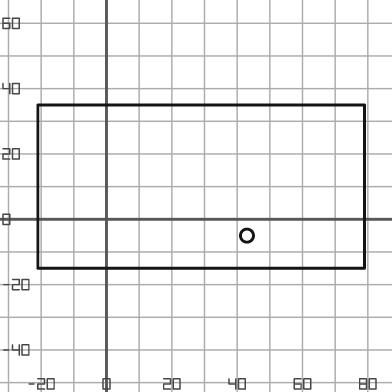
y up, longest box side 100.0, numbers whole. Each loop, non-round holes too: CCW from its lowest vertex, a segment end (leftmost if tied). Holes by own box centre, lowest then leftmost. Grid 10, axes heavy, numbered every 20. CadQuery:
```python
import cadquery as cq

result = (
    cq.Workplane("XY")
    .moveTo(-21.0, -15.0)
    .lineTo(79.0, -15.0)
    .lineTo(79.0, 35.0)
    .lineTo(-21.0, 35.0)
    .close()
    .moveTo(43.0, -5.0)
    .circle(2.0)
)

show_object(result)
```